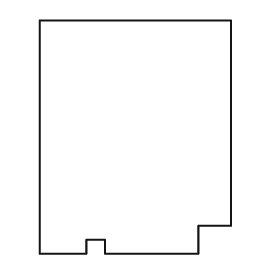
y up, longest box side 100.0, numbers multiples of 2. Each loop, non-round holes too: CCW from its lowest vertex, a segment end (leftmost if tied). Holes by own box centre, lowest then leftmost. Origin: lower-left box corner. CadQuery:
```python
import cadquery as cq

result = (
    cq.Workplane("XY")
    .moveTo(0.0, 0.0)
    .lineTo(20.0, 0.0)
    .lineTo(20.0, 6.0)
    .lineTo(28.0, 6.0)
    .lineTo(28.0, 0.0)
    .lineTo(68.0, 0.0)
    .lineTo(68.0, 12.0)
    .lineTo(82.0, 12.0)
    .lineTo(82.0, 100.0)
    .lineTo(0.0, 100.0)
    .close()
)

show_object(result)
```